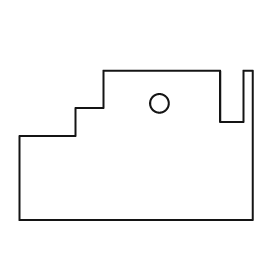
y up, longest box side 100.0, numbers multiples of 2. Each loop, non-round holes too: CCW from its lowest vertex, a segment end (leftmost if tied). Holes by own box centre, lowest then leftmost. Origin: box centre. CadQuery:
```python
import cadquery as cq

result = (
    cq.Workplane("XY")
    .moveTo(-50.0, -32.0)
    .lineTo(50.0, -32.0)
    .lineTo(50.0, 32.0)
    .lineTo(46.0, 32.0)
    .lineTo(46.0, 10.0)
    .lineTo(36.0, 10.0)
    .lineTo(36.0, 32.0)
    .lineTo(-14.0, 32.0)
    .lineTo(-14.0, 16.0)
    .lineTo(-26.0, 16.0)
    .lineTo(-26.0, 4.0)
    .lineTo(-50.0, 4.0)
    .close()
    .moveTo(10.0, 18.0)
    .circle(4.0)
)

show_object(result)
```